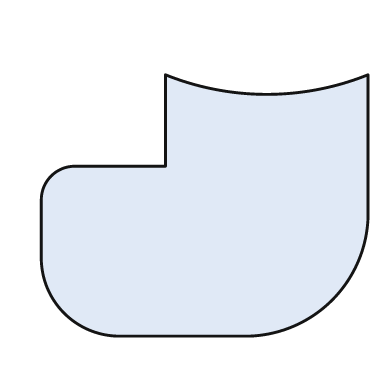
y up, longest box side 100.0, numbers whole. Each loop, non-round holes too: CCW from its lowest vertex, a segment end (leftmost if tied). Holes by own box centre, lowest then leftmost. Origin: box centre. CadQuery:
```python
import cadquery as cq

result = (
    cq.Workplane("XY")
    .moveTo(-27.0, -40.0)
    .lineTo(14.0, -40.0)
    .threePointArc((39.0, -29.0), (50.0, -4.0))
    .lineTo(50.0, 40.0)
    .threePointArc((19.0, 34.0), (-12.0, 40.0))
    .lineTo(-12.0, 12.0)
    .lineTo(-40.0, 12.0)
    .threePointArc((-47.0, 9.0), (-50.0, 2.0))
    .lineTo(-50.0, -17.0)
    .threePointArc((-43.0, -33.0), (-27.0, -40.0))
    .close()
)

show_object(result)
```